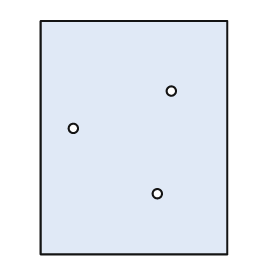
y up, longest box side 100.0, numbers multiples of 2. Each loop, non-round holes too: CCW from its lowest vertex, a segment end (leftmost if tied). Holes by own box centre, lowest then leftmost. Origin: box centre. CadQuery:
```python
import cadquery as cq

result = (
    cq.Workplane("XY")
    .moveTo(-40.0, -50.0)
    .lineTo(40.0, -50.0)
    .lineTo(40.0, 50.0)
    .lineTo(-40.0, 50.0)
    .close()
    .moveTo(10.0, -24.0)
    .circle(2.0)
    .moveTo(-26.0, 4.0)
    .circle(2.0)
    .moveTo(16.0, 20.0)
    .circle(2.0)
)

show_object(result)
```